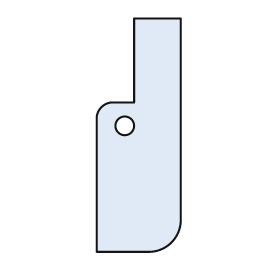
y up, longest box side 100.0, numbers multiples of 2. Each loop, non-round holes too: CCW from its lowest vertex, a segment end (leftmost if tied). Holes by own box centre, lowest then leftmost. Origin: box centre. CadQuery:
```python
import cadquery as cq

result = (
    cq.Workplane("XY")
    .moveTo(-18.0, -50.0)
    .lineTo(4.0, -50.0)
    .threePointArc((14.0, -46.0), (18.0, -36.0))
    .lineTo(18.0, 50.0)
    .lineTo(-2.0, 50.0)
    .lineTo(-2.0, 14.0)
    .lineTo(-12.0, 14.0)
    .threePointArc((-16.0, 12.0), (-18.0, 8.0))
    .close()
    .moveTo(-6.0, 4.0)
    .circle(4.0)
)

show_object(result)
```